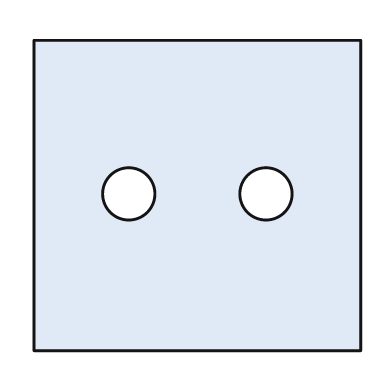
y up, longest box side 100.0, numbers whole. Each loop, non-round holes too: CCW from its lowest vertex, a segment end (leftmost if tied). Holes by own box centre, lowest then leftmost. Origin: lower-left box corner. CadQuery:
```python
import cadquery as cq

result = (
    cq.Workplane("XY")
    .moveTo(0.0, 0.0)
    .lineTo(100.0, 0.0)
    .lineTo(100.0, 95.0)
    .lineTo(0.0, 95.0)
    .close()
    .moveTo(29.0, 48.0)
    .circle(8.0)
    .moveTo(71.0, 48.0)
    .circle(8.0)
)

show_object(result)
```